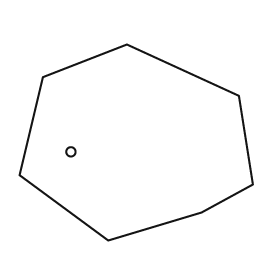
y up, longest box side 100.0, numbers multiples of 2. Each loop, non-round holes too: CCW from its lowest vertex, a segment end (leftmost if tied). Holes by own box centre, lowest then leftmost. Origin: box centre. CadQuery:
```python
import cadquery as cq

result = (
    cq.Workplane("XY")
    .moveTo(-12.0, -42.0)
    .lineTo(28.0, -30.0)
    .lineTo(50.0, -18.0)
    .lineTo(44.0, 20.0)
    .lineTo(-4.0, 42.0)
    .lineTo(-40.0, 28.0)
    .lineTo(-50.0, -14.0)
    .close()
    .moveTo(-28.0, -4.0)
    .circle(2.0)
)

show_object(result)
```